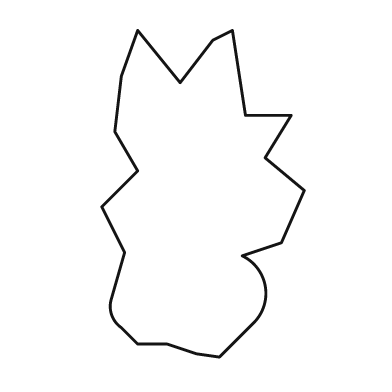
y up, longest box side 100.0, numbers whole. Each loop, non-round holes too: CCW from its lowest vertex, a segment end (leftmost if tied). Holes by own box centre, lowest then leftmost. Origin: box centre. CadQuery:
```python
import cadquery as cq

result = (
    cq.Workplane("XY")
    .moveTo(5.0, -50.0)
    .lineTo(16.0, -39.0)
    .threePointArc((19.0, -28.0), (12.0, -19.0))
    .lineTo(24.0, -15.0)
    .lineTo(31.0, 1.0)
    .lineTo(19.0, 11.0)
    .lineTo(27.0, 24.0)
    .lineTo(13.0, 24.0)
    .lineTo(9.0, 50.0)
    .lineTo(3.0, 47.0)
    .lineTo(-7.0, 34.0)
    .lineTo(-20.0, 50.0)
    .lineTo(-25.0, 36.0)
    .lineTo(-27.0, 19.0)
    .lineTo(-20.0, 7.0)
    .lineTo(-31.0, -4.0)
    .lineTo(-24.0, -18.0)
    .lineTo(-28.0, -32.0)
    .threePointArc((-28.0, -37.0), (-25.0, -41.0))
    .lineTo(-20.0, -46.0)
    .lineTo(-11.0, -46.0)
    .lineTo(-2.0, -49.0)
    .close()
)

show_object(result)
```